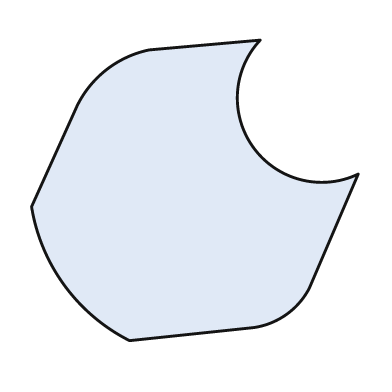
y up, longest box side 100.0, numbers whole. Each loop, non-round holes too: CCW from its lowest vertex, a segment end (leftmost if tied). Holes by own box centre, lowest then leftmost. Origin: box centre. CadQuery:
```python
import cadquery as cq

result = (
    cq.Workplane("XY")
    .moveTo(-20.0, -46.0)
    .lineTo(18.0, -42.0)
    .threePointArc((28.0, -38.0), (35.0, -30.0))
    .lineTo(50.0, 5.0)
    .threePointArc((18.0, 13.0), (20.0, 46.0))
    .lineTo(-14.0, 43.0)
    .threePointArc((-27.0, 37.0), (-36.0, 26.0))
    .lineTo(-50.0, -5.0)
    .threePointArc((-40.0, -29.0), (-20.0, -46.0))
    .close()
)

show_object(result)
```